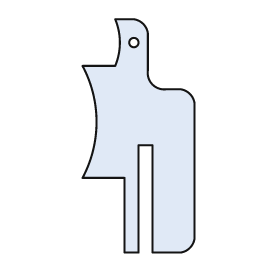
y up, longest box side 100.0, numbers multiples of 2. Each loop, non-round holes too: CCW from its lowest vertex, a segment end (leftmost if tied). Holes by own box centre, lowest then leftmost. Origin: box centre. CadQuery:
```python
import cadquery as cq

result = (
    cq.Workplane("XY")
    .moveTo(-6.0, -50.0)
    .lineTo(0.0, -50.0)
    .lineTo(0.0, -4.0)
    .lineTo(6.0, -4.0)
    .lineTo(6.0, -50.0)
    .lineTo(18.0, -50.0)
    .threePointArc((22.0, -48.0), (24.0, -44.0))
    .lineTo(24.0, 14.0)
    .threePointArc((22.0, 18.0), (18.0, 20.0))
    .lineTo(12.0, 20.0)
    .threePointArc((6.0, 22.0), (4.0, 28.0))
    .lineTo(4.0, 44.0)
    .threePointArc((2.0, 48.0), (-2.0, 50.0))
    .lineTo(-10.0, 50.0)
    .threePointArc((-8.0, 40.0), (-10.0, 30.0))
    .lineTo(-24.0, 30.0)
    .threePointArc((-18.0, 6.0), (-24.0, -18.0))
    .lineTo(-6.0, -18.0)
    .close()
    .moveTo(-2.0, 40.0)
    .circle(2.0)
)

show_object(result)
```